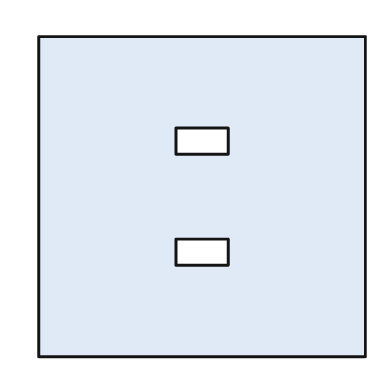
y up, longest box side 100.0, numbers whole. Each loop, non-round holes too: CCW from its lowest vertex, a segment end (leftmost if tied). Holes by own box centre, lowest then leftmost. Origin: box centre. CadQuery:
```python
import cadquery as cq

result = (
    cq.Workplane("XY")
    .moveTo(-50.0, -49.0)
    .lineTo(50.0, -49.0)
    .lineTo(50.0, 49.0)
    .lineTo(-50.0, 49.0)
    .close()
    .moveTo(-8.0, -21.0)
    .lineTo(8.0, -21.0)
    .lineTo(8.0, -13.0)
    .lineTo(-8.0, -13.0)
    .close()
    .moveTo(-8.0, 13.0)
    .lineTo(8.0, 13.0)
    .lineTo(8.0, 21.0)
    .lineTo(-8.0, 21.0)
    .close()
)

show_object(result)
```